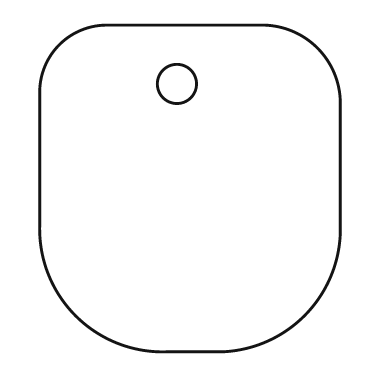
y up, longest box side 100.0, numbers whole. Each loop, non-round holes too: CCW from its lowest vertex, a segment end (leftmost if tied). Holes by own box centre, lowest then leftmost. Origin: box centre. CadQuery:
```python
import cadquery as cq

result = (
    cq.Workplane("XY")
    .moveTo(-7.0, -50.0)
    .lineTo(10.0, -50.0)
    .threePointArc((35.0, -39.0), (46.0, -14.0))
    .lineTo(46.0, 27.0)
    .threePointArc((39.0, 43.0), (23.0, 50.0))
    .lineTo(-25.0, 50.0)
    .threePointArc((-40.0, 44.0), (-46.0, 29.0))
    .lineTo(-46.0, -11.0)
    .threePointArc((-35.0, -39.0), (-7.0, -50.0))
    .close()
    .moveTo(-4.0, 32.0)
    .circle(6.0)
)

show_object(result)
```